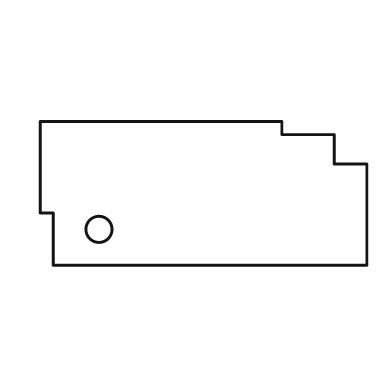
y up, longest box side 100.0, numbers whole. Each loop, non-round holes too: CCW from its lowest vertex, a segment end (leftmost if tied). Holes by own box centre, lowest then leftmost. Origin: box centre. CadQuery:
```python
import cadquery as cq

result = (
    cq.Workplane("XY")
    .moveTo(-46.0, -22.0)
    .lineTo(50.0, -22.0)
    .lineTo(50.0, 9.0)
    .lineTo(40.0, 9.0)
    .lineTo(40.0, 18.0)
    .lineTo(24.0, 18.0)
    .lineTo(24.0, 22.0)
    .lineTo(-50.0, 22.0)
    .lineTo(-50.0, -6.0)
    .lineTo(-46.0, -6.0)
    .close()
    .moveTo(-32.0, -11.0)
    .circle(4.0)
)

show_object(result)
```